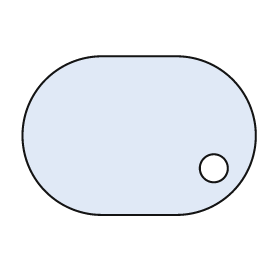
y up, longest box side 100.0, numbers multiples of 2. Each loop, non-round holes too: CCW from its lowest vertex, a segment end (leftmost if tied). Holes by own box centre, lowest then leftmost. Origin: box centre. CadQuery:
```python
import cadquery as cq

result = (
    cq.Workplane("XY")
    .moveTo(-16.0, -34.0)
    .lineTo(16.0, -34.0)
    .threePointArc((50.0, 0.0), (16.0, 34.0))
    .lineTo(-16.0, 34.0)
    .threePointArc((-50.0, 0.0), (-16.0, -34.0))
    .close()
    .moveTo(32.0, -14.0)
    .circle(6.0)
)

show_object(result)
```